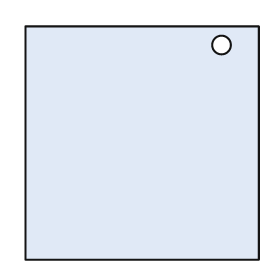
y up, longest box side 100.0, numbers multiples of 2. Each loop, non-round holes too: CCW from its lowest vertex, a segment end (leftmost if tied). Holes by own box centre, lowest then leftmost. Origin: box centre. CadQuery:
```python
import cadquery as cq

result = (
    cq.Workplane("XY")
    .moveTo(-50.0, -50.0)
    .lineTo(50.0, -50.0)
    .lineTo(50.0, 50.0)
    .lineTo(-50.0, 50.0)
    .close()
    .moveTo(34.0, 42.0)
    .circle(4.0)
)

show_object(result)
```